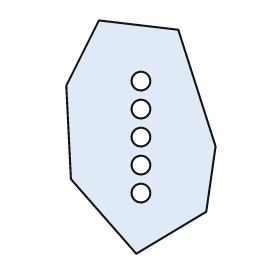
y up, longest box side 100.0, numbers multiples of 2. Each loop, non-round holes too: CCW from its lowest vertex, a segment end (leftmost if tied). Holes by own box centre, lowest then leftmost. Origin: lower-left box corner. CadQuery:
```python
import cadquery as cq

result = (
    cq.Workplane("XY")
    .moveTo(30.0, 0.0)
    .lineTo(60.0, 18.0)
    .lineTo(64.0, 46.0)
    .lineTo(48.0, 96.0)
    .lineTo(14.0, 100.0)
    .lineTo(0.0, 72.0)
    .lineTo(2.0, 32.0)
    .close()
    .moveTo(32.0, 26.0)
    .circle(4.0)
    .moveTo(32.0, 38.0)
    .circle(4.0)
    .moveTo(32.0, 50.0)
    .circle(4.0)
    .moveTo(32.0, 62.0)
    .circle(4.0)
    .moveTo(32.0, 74.0)
    .circle(4.0)
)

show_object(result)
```